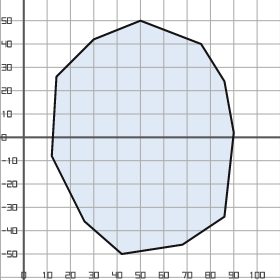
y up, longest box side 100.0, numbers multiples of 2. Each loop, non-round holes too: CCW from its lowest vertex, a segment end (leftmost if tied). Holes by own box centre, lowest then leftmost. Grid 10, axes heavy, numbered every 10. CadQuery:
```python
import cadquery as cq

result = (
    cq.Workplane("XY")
    .moveTo(42.0, -50.0)
    .lineTo(68.0, -46.0)
    .lineTo(86.0, -34.0)
    .lineTo(90.0, 2.0)
    .lineTo(86.0, 24.0)
    .lineTo(76.0, 40.0)
    .lineTo(50.0, 50.0)
    .lineTo(30.0, 42.0)
    .lineTo(14.0, 26.0)
    .lineTo(12.0, -8.0)
    .lineTo(26.0, -36.0)
    .close()
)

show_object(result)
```